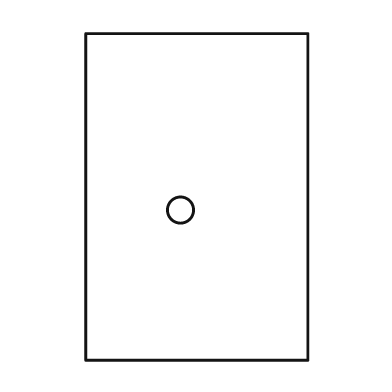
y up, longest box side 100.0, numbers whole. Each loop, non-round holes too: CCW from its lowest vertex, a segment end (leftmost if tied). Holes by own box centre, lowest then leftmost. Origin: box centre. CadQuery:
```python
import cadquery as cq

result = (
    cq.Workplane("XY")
    .moveTo(-34.0, -50.0)
    .lineTo(34.0, -50.0)
    .lineTo(34.0, 50.0)
    .lineTo(-34.0, 50.0)
    .close()
    .moveTo(-5.0, -4.0)
    .circle(4.0)
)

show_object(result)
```